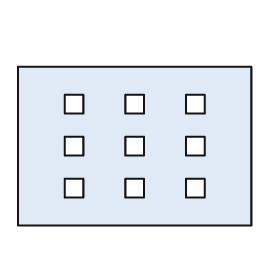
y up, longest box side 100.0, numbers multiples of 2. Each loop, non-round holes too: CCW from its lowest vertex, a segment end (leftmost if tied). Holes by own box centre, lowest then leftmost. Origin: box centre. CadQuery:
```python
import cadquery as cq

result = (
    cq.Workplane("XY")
    .moveTo(-50.0, -34.0)
    .lineTo(50.0, -34.0)
    .lineTo(50.0, 34.0)
    .lineTo(-50.0, 34.0)
    .close()
    .moveTo(-30.0, -22.0)
    .lineTo(-22.0, -22.0)
    .lineTo(-22.0, -14.0)
    .lineTo(-30.0, -14.0)
    .close()
    .moveTo(-4.0, -22.0)
    .lineTo(4.0, -22.0)
    .lineTo(4.0, -14.0)
    .lineTo(-4.0, -14.0)
    .close()
    .moveTo(22.0, -22.0)
    .lineTo(30.0, -22.0)
    .lineTo(30.0, -14.0)
    .lineTo(22.0, -14.0)
    .close()
    .moveTo(-30.0, -4.0)
    .lineTo(-22.0, -4.0)
    .lineTo(-22.0, 4.0)
    .lineTo(-30.0, 4.0)
    .close()
    .moveTo(-4.0, -4.0)
    .lineTo(4.0, -4.0)
    .lineTo(4.0, 4.0)
    .lineTo(-4.0, 4.0)
    .close()
    .moveTo(22.0, -4.0)
    .lineTo(30.0, -4.0)
    .lineTo(30.0, 4.0)
    .lineTo(22.0, 4.0)
    .close()
    .moveTo(-30.0, 14.0)
    .lineTo(-22.0, 14.0)
    .lineTo(-22.0, 22.0)
    .lineTo(-30.0, 22.0)
    .close()
    .moveTo(-4.0, 14.0)
    .lineTo(4.0, 14.0)
    .lineTo(4.0, 22.0)
    .lineTo(-4.0, 22.0)
    .close()
    .moveTo(22.0, 14.0)
    .lineTo(30.0, 14.0)
    .lineTo(30.0, 22.0)
    .lineTo(22.0, 22.0)
    .close()
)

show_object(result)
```